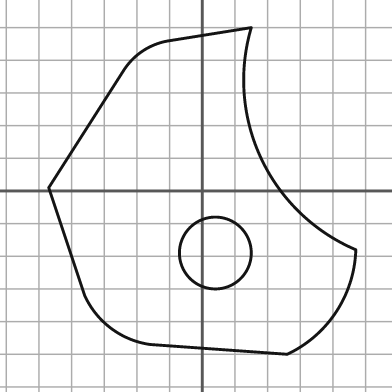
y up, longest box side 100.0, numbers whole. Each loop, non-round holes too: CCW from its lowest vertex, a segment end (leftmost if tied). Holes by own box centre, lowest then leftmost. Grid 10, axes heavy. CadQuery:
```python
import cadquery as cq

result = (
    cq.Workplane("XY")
    .moveTo(26.0, -50.0)
    .threePointArc((41.0, -37.0), (47.0, -18.0))
    .threePointArc((18.0, 10.0), (15.0, 50.0))
    .lineTo(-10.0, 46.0)
    .threePointArc((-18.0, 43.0), (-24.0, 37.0))
    .lineTo(-47.0, 1.0)
    .lineTo(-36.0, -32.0)
    .threePointArc((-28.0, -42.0), (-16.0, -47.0))
    .close()
    .moveTo(4.0, -19.0)
    .circle(11.0)
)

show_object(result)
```